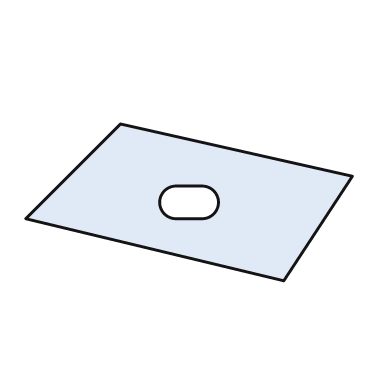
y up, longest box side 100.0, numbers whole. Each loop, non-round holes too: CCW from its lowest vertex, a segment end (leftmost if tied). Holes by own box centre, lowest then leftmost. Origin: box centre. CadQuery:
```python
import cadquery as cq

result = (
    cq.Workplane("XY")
    .moveTo(29.0, -24.0)
    .lineTo(50.0, 8.0)
    .lineTo(-21.0, 24.0)
    .lineTo(-50.0, -5.0)
    .close()
    .moveTo(-4.0, -5.0)
    .lineTo(4.0, -5.0)
    .threePointArc((9.0, 0.0), (4.0, 5.0))
    .lineTo(-4.0, 5.0)
    .threePointArc((-9.0, 0.0), (-4.0, -5.0))
    .close()
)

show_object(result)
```